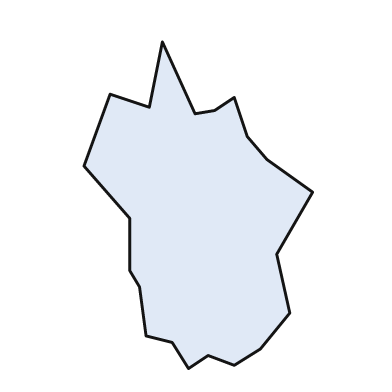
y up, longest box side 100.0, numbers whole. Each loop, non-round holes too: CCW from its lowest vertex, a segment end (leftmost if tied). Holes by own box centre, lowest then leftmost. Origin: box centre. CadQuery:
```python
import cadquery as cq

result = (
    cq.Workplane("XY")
    .moveTo(-3.0, -50.0)
    .lineTo(3.0, -46.0)
    .lineTo(11.0, -49.0)
    .lineTo(19.0, -44.0)
    .lineTo(28.0, -33.0)
    .lineTo(24.0, -15.0)
    .lineTo(35.0, 4.0)
    .lineTo(21.0, 14.0)
    .lineTo(15.0, 21.0)
    .lineTo(11.0, 33.0)
    .lineTo(5.0, 29.0)
    .lineTo(-1.0, 28.0)
    .lineTo(-11.0, 50.0)
    .lineTo(-15.0, 30.0)
    .lineTo(-27.0, 34.0)
    .lineTo(-35.0, 12.0)
    .lineTo(-21.0, -4.0)
    .lineTo(-21.0, -20.0)
    .lineTo(-18.0, -25.0)
    .lineTo(-16.0, -40.0)
    .lineTo(-8.0, -42.0)
    .close()
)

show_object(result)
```